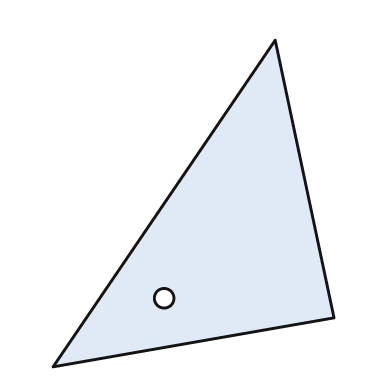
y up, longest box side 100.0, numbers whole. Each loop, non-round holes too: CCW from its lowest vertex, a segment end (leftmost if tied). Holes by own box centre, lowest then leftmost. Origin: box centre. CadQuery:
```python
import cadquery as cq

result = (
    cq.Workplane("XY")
    .moveTo(-43.0, -50.0)
    .lineTo(43.0, -35.0)
    .lineTo(25.0, 50.0)
    .close()
    .moveTo(-9.0, -29.0)
    .circle(3.0)
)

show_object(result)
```